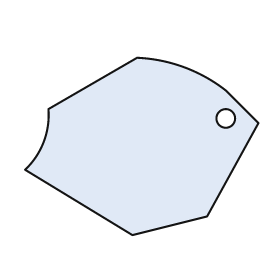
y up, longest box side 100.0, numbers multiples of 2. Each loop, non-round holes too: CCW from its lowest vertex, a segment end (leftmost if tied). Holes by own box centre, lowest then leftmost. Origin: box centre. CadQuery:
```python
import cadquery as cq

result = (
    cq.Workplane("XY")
    .moveTo(-4.0, -38.0)
    .lineTo(28.0, -30.0)
    .lineTo(50.0, 10.0)
    .lineTo(36.0, 24.0)
    .threePointArc((18.0, 34.0), (-2.0, 38.0))
    .lineTo(-40.0, 16.0)
    .threePointArc((-42.0, 2.0), (-50.0, -10.0))
    .close()
    .moveTo(36.0, 12.0)
    .circle(4.0)
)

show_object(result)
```